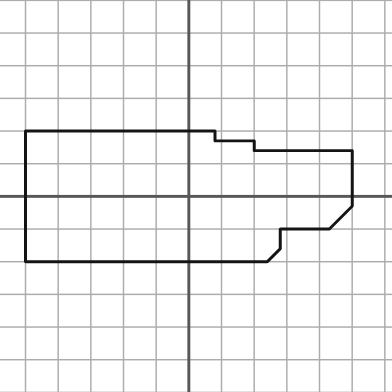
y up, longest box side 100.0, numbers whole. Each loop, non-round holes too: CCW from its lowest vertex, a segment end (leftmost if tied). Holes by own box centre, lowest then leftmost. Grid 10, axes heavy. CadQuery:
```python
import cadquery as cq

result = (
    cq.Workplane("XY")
    .moveTo(-50.0, -20.0)
    .lineTo(24.0, -20.0)
    .lineTo(28.0, -16.0)
    .lineTo(28.0, -10.0)
    .lineTo(43.0, -10.0)
    .lineTo(50.0, -3.0)
    .lineTo(50.0, 14.0)
    .lineTo(20.0, 14.0)
    .lineTo(20.0, 17.0)
    .lineTo(8.0, 17.0)
    .lineTo(8.0, 20.0)
    .lineTo(-50.0, 20.0)
    .close()
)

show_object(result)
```